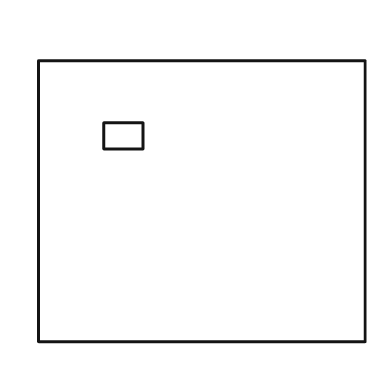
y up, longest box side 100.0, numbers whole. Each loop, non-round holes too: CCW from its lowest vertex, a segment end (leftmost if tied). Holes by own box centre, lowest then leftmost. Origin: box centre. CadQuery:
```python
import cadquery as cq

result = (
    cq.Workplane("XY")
    .moveTo(-50.0, -43.0)
    .lineTo(50.0, -43.0)
    .lineTo(50.0, 43.0)
    .lineTo(-50.0, 43.0)
    .close()
    .moveTo(-30.0, 16.0)
    .lineTo(-18.0, 16.0)
    .lineTo(-18.0, 24.0)
    .lineTo(-30.0, 24.0)
    .close()
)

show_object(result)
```